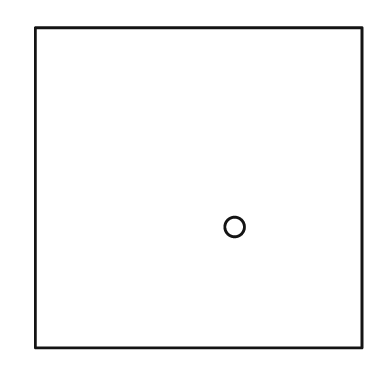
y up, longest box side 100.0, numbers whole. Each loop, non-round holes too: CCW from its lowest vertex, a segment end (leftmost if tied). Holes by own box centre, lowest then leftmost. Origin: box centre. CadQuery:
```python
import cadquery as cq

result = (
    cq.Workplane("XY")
    .moveTo(-50.0, -49.0)
    .lineTo(50.0, -49.0)
    .lineTo(50.0, 49.0)
    .lineTo(-50.0, 49.0)
    .close()
    .moveTo(11.0, -12.0)
    .circle(3.0)
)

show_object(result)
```